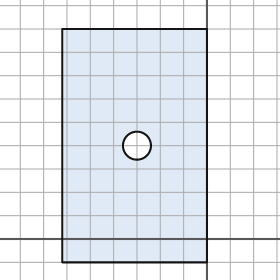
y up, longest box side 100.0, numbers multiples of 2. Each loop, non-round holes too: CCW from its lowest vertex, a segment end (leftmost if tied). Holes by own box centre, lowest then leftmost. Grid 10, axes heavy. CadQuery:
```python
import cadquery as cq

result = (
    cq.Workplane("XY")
    .moveTo(-62.0, -10.0)
    .lineTo(0.0, -10.0)
    .lineTo(0.0, 90.0)
    .lineTo(-62.0, 90.0)
    .close()
    .moveTo(-30.0, 40.0)
    .circle(6.0)
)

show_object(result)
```